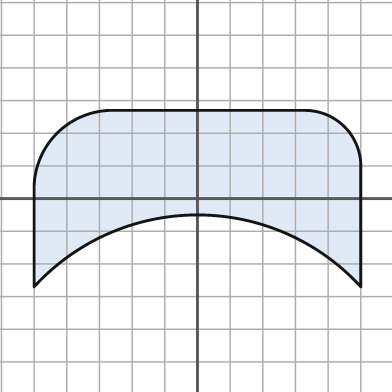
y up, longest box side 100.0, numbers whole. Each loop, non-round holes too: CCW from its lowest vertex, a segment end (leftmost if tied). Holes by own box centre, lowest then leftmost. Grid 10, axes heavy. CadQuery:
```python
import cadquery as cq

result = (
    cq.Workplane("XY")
    .moveTo(-50.0, -27.0)
    .threePointArc((0.0, -5.0), (50.0, -27.0))
    .lineTo(50.0, 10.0)
    .threePointArc((45.0, 22.0), (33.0, 27.0))
    .lineTo(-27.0, 27.0)
    .threePointArc((-43.0, 20.0), (-50.0, 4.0))
    .close()
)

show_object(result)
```